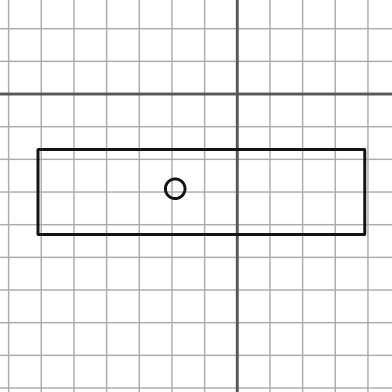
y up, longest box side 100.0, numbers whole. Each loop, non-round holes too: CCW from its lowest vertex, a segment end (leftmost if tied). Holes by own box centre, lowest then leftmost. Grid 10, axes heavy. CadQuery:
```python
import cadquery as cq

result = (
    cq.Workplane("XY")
    .moveTo(-61.0, -43.0)
    .lineTo(39.0, -43.0)
    .lineTo(39.0, -17.0)
    .lineTo(-61.0, -17.0)
    .close()
    .moveTo(-19.0, -29.0)
    .circle(3.0)
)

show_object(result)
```